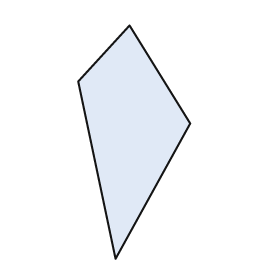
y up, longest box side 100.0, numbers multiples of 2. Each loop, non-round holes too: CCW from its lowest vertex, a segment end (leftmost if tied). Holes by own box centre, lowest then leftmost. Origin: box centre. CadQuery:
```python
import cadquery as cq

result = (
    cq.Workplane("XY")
    .moveTo(-8.0, -50.0)
    .lineTo(24.0, 8.0)
    .lineTo(-2.0, 50.0)
    .lineTo(-24.0, 26.0)
    .close()
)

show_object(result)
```